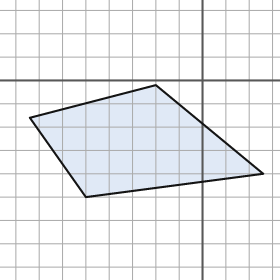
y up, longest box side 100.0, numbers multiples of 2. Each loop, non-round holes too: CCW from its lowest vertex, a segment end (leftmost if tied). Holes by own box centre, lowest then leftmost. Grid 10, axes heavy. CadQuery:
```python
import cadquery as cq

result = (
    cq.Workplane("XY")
    .moveTo(-50.0, -50.0)
    .lineTo(26.0, -40.0)
    .lineTo(-20.0, -2.0)
    .lineTo(-74.0, -16.0)
    .close()
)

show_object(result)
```